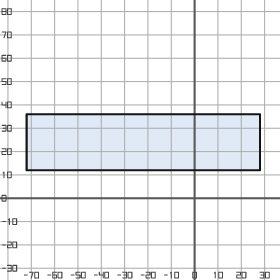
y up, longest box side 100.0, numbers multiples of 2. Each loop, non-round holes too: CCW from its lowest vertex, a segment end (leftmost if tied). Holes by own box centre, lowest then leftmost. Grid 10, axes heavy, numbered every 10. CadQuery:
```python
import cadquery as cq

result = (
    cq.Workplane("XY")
    .moveTo(-72.0, 12.0)
    .lineTo(28.0, 12.0)
    .lineTo(28.0, 36.0)
    .lineTo(-72.0, 36.0)
    .close()
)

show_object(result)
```